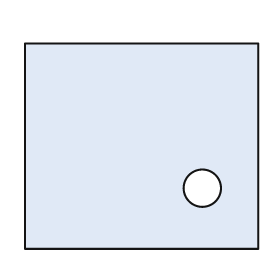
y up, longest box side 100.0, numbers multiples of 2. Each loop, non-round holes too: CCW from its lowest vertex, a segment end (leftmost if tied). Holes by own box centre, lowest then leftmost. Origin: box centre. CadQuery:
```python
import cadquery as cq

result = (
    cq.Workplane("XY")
    .moveTo(-50.0, -44.0)
    .lineTo(50.0, -44.0)
    .lineTo(50.0, 44.0)
    .lineTo(-50.0, 44.0)
    .close()
    .moveTo(26.0, -18.0)
    .circle(8.0)
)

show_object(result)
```